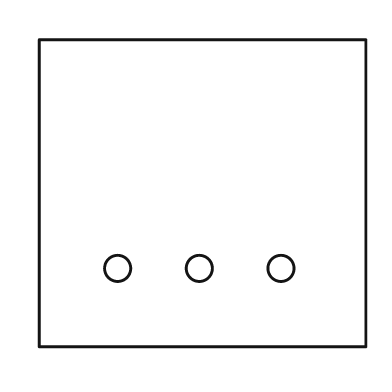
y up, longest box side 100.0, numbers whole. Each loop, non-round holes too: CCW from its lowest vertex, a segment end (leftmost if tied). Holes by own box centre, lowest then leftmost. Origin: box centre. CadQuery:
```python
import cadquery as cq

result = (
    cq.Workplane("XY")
    .moveTo(-50.0, -47.0)
    .lineTo(50.0, -47.0)
    .lineTo(50.0, 47.0)
    .lineTo(-50.0, 47.0)
    .close()
    .moveTo(-26.0, -23.0)
    .circle(4.0)
    .moveTo(-1.0, -23.0)
    .circle(4.0)
    .moveTo(24.0, -23.0)
    .circle(4.0)
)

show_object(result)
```